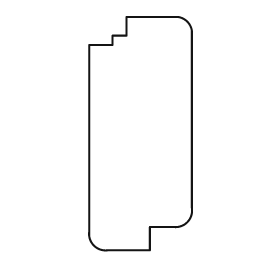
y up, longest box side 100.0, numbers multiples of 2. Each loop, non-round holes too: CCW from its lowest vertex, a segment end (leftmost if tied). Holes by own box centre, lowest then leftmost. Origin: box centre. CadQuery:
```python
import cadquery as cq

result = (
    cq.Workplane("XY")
    .moveTo(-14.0, -50.0)
    .lineTo(4.0, -50.0)
    .lineTo(4.0, -40.0)
    .lineTo(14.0, -40.0)
    .threePointArc((20.0, -38.0), (22.0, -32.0))
    .lineTo(22.0, 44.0)
    .threePointArc((20.0, 48.0), (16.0, 50.0))
    .lineTo(-6.0, 50.0)
    .lineTo(-6.0, 42.0)
    .lineTo(-12.0, 42.0)
    .lineTo(-12.0, 38.0)
    .lineTo(-22.0, 38.0)
    .lineTo(-22.0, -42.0)
    .threePointArc((-20.0, -48.0), (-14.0, -50.0))
    .close()
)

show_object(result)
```